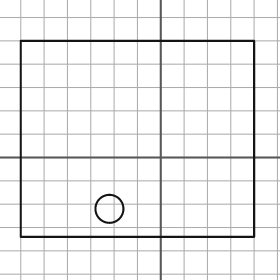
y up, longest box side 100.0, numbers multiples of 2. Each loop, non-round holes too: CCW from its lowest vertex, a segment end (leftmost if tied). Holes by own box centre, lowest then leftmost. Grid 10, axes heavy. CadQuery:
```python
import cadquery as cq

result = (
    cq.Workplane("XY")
    .moveTo(-60.0, -34.0)
    .lineTo(40.0, -34.0)
    .lineTo(40.0, 50.0)
    .lineTo(-60.0, 50.0)
    .close()
    .moveTo(-22.0, -22.0)
    .circle(6.0)
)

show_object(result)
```